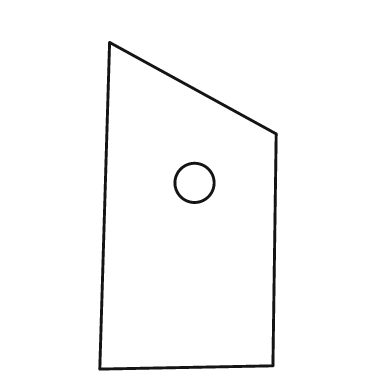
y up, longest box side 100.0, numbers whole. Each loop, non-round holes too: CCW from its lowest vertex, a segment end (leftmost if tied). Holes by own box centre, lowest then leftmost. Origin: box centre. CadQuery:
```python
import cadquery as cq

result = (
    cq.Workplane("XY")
    .moveTo(-27.0, -50.0)
    .lineTo(26.0, -49.0)
    .lineTo(27.0, 22.0)
    .lineTo(-24.0, 50.0)
    .close()
    .moveTo(2.0, 7.0)
    .circle(6.0)
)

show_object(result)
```